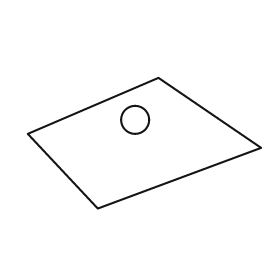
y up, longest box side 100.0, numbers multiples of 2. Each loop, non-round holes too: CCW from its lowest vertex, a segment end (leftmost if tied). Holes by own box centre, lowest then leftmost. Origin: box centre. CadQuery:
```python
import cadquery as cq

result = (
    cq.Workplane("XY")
    .moveTo(-20.0, -28.0)
    .lineTo(50.0, -2.0)
    .lineTo(6.0, 28.0)
    .lineTo(-50.0, 4.0)
    .close()
    .moveTo(-4.0, 10.0)
    .circle(6.0)
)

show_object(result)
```